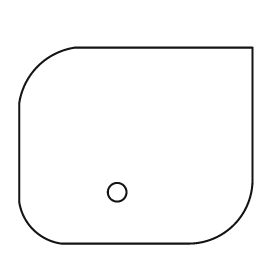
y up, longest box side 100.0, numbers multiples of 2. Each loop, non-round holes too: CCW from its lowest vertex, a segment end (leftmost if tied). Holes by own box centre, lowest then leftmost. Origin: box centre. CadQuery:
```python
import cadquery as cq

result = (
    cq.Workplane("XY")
    .moveTo(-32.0, -42.0)
    .lineTo(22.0, -42.0)
    .threePointArc((42.0, -34.0), (50.0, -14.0))
    .lineTo(50.0, 42.0)
    .lineTo(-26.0, 42.0)
    .threePointArc((-42.0, 34.0), (-50.0, 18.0))
    .lineTo(-50.0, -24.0)
    .threePointArc((-44.0, -36.0), (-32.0, -42.0))
    .close()
    .moveTo(-8.0, -20.0)
    .circle(4.0)
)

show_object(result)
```